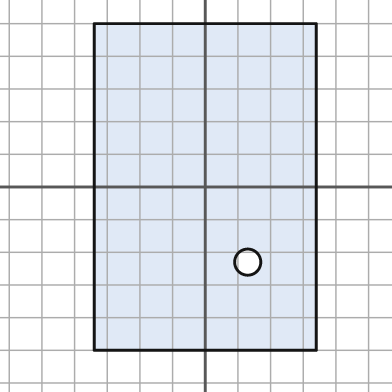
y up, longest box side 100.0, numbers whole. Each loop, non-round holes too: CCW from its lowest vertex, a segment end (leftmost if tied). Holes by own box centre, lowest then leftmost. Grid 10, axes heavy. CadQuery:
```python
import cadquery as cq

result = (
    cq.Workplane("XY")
    .moveTo(-34.0, -50.0)
    .lineTo(34.0, -50.0)
    .lineTo(34.0, 50.0)
    .lineTo(-34.0, 50.0)
    .close()
    .moveTo(13.0, -23.0)
    .circle(4.0)
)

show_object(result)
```